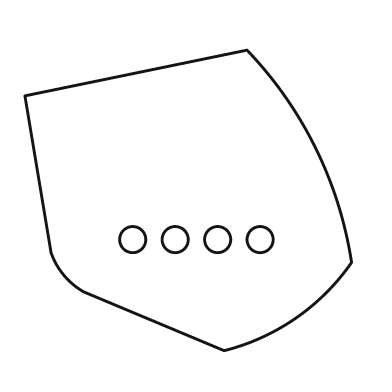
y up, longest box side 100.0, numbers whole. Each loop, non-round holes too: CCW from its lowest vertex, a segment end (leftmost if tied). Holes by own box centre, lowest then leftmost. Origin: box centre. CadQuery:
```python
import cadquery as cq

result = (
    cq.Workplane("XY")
    .moveTo(11.0, -46.0)
    .threePointArc((33.0, -36.0), (50.0, -19.0))
    .threePointArc((39.0, 16.0), (18.0, 46.0))
    .lineTo(-50.0, 32.0)
    .lineTo(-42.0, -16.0)
    .threePointArc((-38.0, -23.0), (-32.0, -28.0))
    .close()
    .moveTo(-17.0, -12.0)
    .circle(4.0)
    .moveTo(-4.0, -12.0)
    .circle(4.0)
    .moveTo(9.0, -12.0)
    .circle(4.0)
    .moveTo(22.0, -12.0)
    .circle(4.0)
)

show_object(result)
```